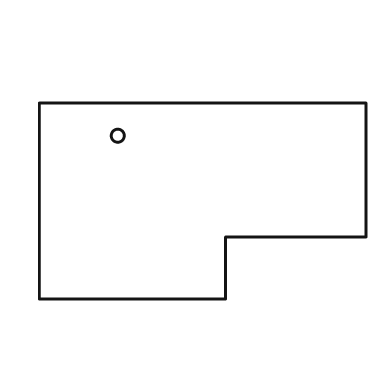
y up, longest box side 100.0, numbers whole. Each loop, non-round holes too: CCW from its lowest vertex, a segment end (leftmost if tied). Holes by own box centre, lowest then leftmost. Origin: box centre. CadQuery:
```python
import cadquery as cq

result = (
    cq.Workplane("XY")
    .moveTo(-50.0, -30.0)
    .lineTo(7.0, -30.0)
    .lineTo(7.0, -11.0)
    .lineTo(50.0, -11.0)
    .lineTo(50.0, 30.0)
    .lineTo(-50.0, 30.0)
    .close()
    .moveTo(-26.0, 20.0)
    .circle(2.0)
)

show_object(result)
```